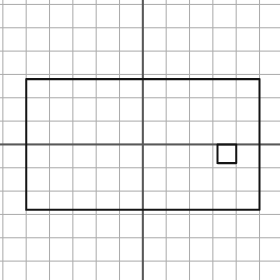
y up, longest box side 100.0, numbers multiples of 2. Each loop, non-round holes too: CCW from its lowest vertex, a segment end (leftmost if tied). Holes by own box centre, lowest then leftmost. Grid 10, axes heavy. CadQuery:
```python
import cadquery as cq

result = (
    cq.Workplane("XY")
    .moveTo(-50.0, -28.0)
    .lineTo(50.0, -28.0)
    .lineTo(50.0, 28.0)
    .lineTo(-50.0, 28.0)
    .close()
    .moveTo(32.0, -8.0)
    .lineTo(40.0, -8.0)
    .lineTo(40.0, 0.0)
    .lineTo(32.0, 0.0)
    .close()
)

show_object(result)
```